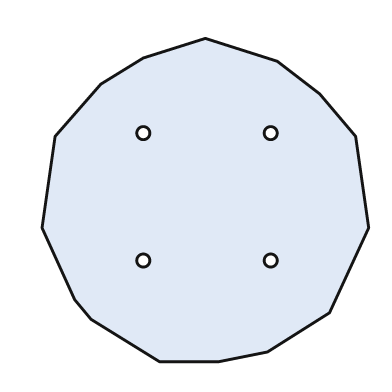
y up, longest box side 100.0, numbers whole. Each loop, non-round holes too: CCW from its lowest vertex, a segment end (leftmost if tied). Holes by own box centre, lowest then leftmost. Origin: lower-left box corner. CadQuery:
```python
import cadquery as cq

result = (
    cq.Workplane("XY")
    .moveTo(36.0, 0.0)
    .lineTo(54.0, 0.0)
    .lineTo(69.0, 3.0)
    .lineTo(88.0, 15.0)
    .lineTo(100.0, 41.0)
    .lineTo(96.0, 69.0)
    .lineTo(85.0, 82.0)
    .lineTo(72.0, 92.0)
    .lineTo(50.0, 99.0)
    .lineTo(31.0, 93.0)
    .lineTo(18.0, 85.0)
    .lineTo(4.0, 69.0)
    .lineTo(0.0, 41.0)
    .lineTo(10.0, 19.0)
    .lineTo(15.0, 13.0)
    .close()
    .moveTo(31.0, 31.0)
    .circle(2.0)
    .moveTo(70.0, 31.0)
    .circle(2.0)
    .moveTo(31.0, 70.0)
    .circle(2.0)
    .moveTo(70.0, 70.0)
    .circle(2.0)
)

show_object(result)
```